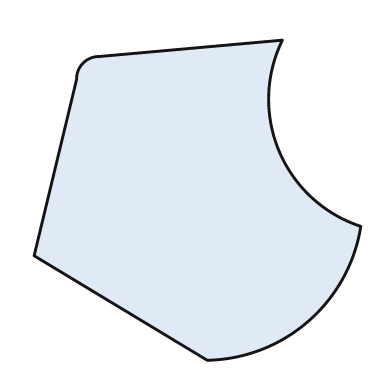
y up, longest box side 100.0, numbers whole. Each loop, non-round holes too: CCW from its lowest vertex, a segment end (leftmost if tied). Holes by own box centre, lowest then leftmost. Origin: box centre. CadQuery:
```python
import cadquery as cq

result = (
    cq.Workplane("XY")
    .moveTo(3.0, -49.0)
    .threePointArc((34.0, -37.0), (50.0, -8.0))
    .threePointArc((25.0, 15.0), (26.0, 49.0))
    .lineTo(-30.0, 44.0)
    .threePointArc((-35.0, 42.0), (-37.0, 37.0))
    .lineTo(-50.0, -17.0)
    .close()
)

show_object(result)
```